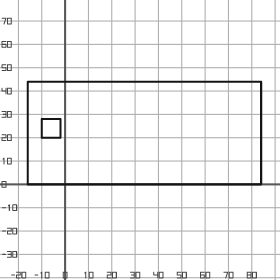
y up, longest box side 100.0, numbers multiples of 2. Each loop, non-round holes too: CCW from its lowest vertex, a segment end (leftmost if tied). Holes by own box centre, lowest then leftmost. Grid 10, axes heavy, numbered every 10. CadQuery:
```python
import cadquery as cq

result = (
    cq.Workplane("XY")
    .moveTo(-16.0, 0.0)
    .lineTo(84.0, 0.0)
    .lineTo(84.0, 44.0)
    .lineTo(-16.0, 44.0)
    .close()
    .moveTo(-10.0, 20.0)
    .lineTo(-2.0, 20.0)
    .lineTo(-2.0, 28.0)
    .lineTo(-10.0, 28.0)
    .close()
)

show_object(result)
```